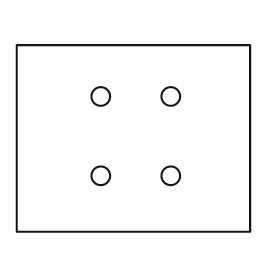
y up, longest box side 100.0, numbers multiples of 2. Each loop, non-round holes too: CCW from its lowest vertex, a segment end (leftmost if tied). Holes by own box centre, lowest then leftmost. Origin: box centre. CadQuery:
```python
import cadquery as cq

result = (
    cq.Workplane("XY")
    .moveTo(-50.0, -40.0)
    .lineTo(50.0, -40.0)
    .lineTo(50.0, 40.0)
    .lineTo(-50.0, 40.0)
    .close()
    .moveTo(-14.0, -16.0)
    .circle(4.0)
    .moveTo(16.0, -16.0)
    .circle(4.0)
    .moveTo(-14.0, 18.0)
    .circle(4.0)
    .moveTo(16.0, 18.0)
    .circle(4.0)
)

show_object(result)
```